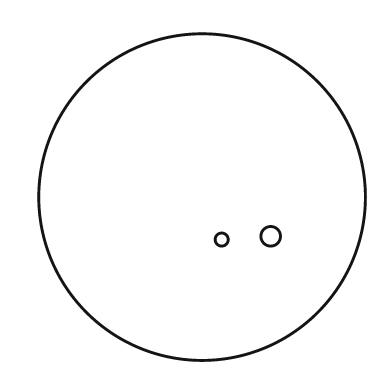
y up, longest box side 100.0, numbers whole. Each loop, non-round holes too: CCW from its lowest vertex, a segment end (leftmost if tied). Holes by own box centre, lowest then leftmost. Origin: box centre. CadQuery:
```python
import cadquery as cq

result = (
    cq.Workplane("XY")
    .moveTo(0.0, 0.0)
    .circle(50.0)
    .moveTo(6.0, -13.0)
    .circle(2.0)
    .moveTo(21.0, -12.0)
    .circle(3.0)
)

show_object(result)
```